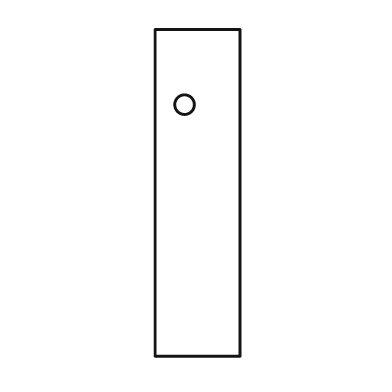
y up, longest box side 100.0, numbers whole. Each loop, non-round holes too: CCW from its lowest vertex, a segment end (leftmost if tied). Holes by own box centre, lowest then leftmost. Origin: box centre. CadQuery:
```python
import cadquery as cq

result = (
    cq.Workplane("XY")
    .moveTo(-13.0, -50.0)
    .lineTo(13.0, -50.0)
    .lineTo(13.0, 50.0)
    .lineTo(-13.0, 50.0)
    .close()
    .moveTo(-4.0, 27.0)
    .circle(3.0)
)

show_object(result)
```